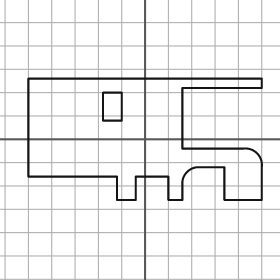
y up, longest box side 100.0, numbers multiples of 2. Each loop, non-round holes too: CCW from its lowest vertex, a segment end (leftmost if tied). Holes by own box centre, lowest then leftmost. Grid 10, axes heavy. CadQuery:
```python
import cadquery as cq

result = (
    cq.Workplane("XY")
    .moveTo(-12.0, -26.0)
    .lineTo(-4.0, -26.0)
    .lineTo(-4.0, -16.0)
    .lineTo(10.0, -16.0)
    .lineTo(10.0, -26.0)
    .lineTo(16.0, -26.0)
    .lineTo(16.0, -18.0)
    .threePointArc((18.0, -14.0), (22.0, -12.0))
    .lineTo(34.0, -12.0)
    .lineTo(34.0, -26.0)
    .lineTo(50.0, -26.0)
    .lineTo(50.0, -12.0)
    .threePointArc((48.0, -6.0), (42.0, -4.0))
    .lineTo(16.0, -4.0)
    .lineTo(16.0, 22.0)
    .lineTo(50.0, 22.0)
    .lineTo(50.0, 26.0)
    .lineTo(-50.0, 26.0)
    .lineTo(-50.0, -16.0)
    .lineTo(-12.0, -16.0)
    .close()
    .moveTo(-18.0, 8.0)
    .lineTo(-10.0, 8.0)
    .lineTo(-10.0, 20.0)
    .lineTo(-18.0, 20.0)
    .close()
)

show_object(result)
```